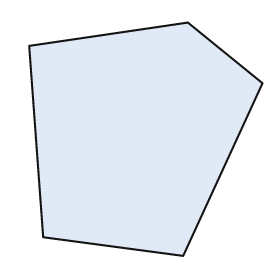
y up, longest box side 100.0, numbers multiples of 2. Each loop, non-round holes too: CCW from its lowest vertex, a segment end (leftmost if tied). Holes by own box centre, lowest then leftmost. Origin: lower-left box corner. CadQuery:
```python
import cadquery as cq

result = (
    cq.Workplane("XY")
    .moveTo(66.0, 0.0)
    .lineTo(100.0, 74.0)
    .lineTo(68.0, 100.0)
    .lineTo(0.0, 90.0)
    .lineTo(6.0, 8.0)
    .close()
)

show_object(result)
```